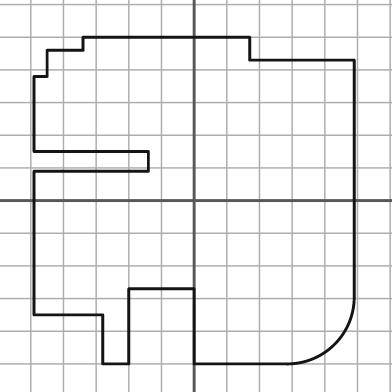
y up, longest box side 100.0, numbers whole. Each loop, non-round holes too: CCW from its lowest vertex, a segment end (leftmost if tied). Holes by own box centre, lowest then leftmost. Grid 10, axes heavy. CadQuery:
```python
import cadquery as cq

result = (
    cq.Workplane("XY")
    .moveTo(-28.0, -50.0)
    .lineTo(-20.0, -50.0)
    .lineTo(-20.0, -27.0)
    .lineTo(0.0, -27.0)
    .lineTo(0.0, -50.0)
    .lineTo(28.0, -50.0)
    .threePointArc((43.0, -44.0), (49.0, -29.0))
    .lineTo(49.0, 43.0)
    .lineTo(17.0, 43.0)
    .lineTo(17.0, 50.0)
    .lineTo(-34.0, 50.0)
    .lineTo(-34.0, 46.0)
    .lineTo(-45.0, 46.0)
    .lineTo(-45.0, 38.0)
    .lineTo(-49.0, 38.0)
    .lineTo(-49.0, 15.0)
    .lineTo(-14.0, 15.0)
    .lineTo(-14.0, 9.0)
    .lineTo(-49.0, 9.0)
    .lineTo(-49.0, -35.0)
    .lineTo(-28.0, -35.0)
    .close()
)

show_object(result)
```